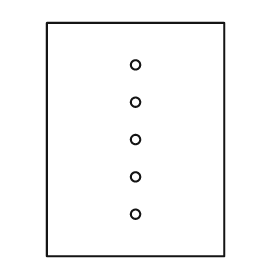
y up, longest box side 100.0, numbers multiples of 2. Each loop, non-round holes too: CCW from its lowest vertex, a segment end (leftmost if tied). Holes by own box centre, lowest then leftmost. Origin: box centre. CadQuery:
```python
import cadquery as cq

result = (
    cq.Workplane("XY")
    .moveTo(-38.0, -50.0)
    .lineTo(38.0, -50.0)
    .lineTo(38.0, 50.0)
    .lineTo(-38.0, 50.0)
    .close()
    .moveTo(0.0, -32.0)
    .circle(2.0)
    .moveTo(0.0, -16.0)
    .circle(2.0)
    .moveTo(0.0, 0.0)
    .circle(2.0)
    .moveTo(0.0, 16.0)
    .circle(2.0)
    .moveTo(0.0, 32.0)
    .circle(2.0)
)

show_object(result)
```